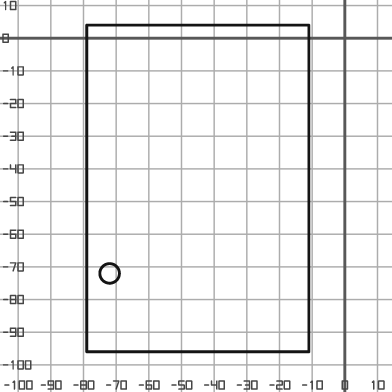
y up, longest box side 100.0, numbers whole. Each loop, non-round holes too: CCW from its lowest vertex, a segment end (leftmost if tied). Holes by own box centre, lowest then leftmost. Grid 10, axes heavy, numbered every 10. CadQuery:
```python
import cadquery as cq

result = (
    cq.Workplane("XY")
    .moveTo(-79.0, -96.0)
    .lineTo(-11.0, -96.0)
    .lineTo(-11.0, 4.0)
    .lineTo(-79.0, 4.0)
    .close()
    .moveTo(-72.0, -72.0)
    .circle(3.0)
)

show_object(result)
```